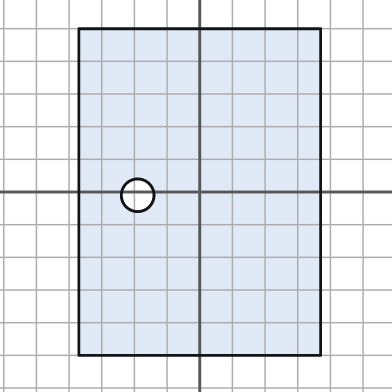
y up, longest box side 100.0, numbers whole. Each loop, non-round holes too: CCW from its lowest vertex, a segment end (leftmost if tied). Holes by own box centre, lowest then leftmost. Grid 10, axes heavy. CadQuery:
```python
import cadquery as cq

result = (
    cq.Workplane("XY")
    .moveTo(-37.0, -50.0)
    .lineTo(37.0, -50.0)
    .lineTo(37.0, 50.0)
    .lineTo(-37.0, 50.0)
    .close()
    .moveTo(-19.0, -1.0)
    .circle(5.0)
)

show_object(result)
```